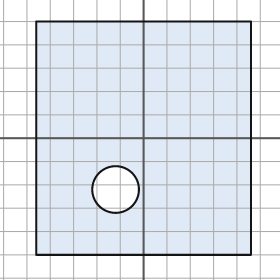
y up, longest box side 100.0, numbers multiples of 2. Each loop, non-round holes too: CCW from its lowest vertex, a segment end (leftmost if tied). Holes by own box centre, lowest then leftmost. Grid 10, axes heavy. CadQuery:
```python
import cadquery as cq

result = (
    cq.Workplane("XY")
    .moveTo(-46.0, -50.0)
    .lineTo(46.0, -50.0)
    .lineTo(46.0, 50.0)
    .lineTo(-46.0, 50.0)
    .close()
    .moveTo(-12.0, -22.0)
    .circle(10.0)
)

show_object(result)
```